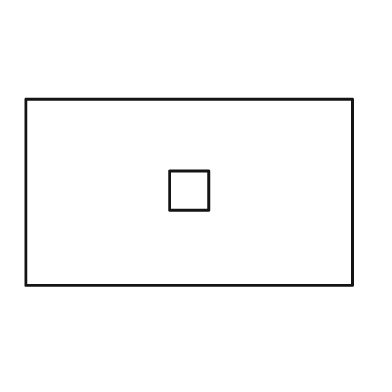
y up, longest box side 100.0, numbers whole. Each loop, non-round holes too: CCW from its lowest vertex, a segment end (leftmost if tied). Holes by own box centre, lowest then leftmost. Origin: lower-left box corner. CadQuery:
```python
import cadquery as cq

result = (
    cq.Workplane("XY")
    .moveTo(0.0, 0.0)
    .lineTo(100.0, 0.0)
    .lineTo(100.0, 57.0)
    .lineTo(0.0, 57.0)
    .close()
    .moveTo(44.0, 23.0)
    .lineTo(56.0, 23.0)
    .lineTo(56.0, 35.0)
    .lineTo(44.0, 35.0)
    .close()
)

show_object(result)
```